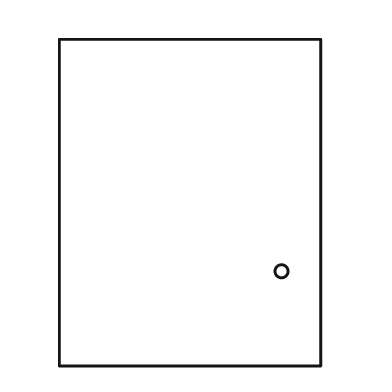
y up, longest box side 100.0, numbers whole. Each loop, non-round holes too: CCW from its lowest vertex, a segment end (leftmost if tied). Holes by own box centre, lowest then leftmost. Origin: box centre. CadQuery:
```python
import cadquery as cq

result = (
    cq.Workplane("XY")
    .moveTo(-40.0, -50.0)
    .lineTo(40.0, -50.0)
    .lineTo(40.0, 50.0)
    .lineTo(-40.0, 50.0)
    .close()
    .moveTo(28.0, -21.0)
    .circle(2.0)
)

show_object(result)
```